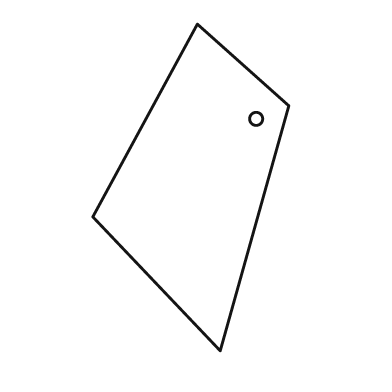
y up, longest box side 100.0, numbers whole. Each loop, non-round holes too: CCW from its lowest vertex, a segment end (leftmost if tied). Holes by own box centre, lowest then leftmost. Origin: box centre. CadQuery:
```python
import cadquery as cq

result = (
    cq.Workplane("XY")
    .moveTo(9.0, -50.0)
    .lineTo(30.0, 25.0)
    .lineTo(2.0, 50.0)
    .lineTo(-30.0, -9.0)
    .close()
    .moveTo(20.0, 21.0)
    .circle(2.0)
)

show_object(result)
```